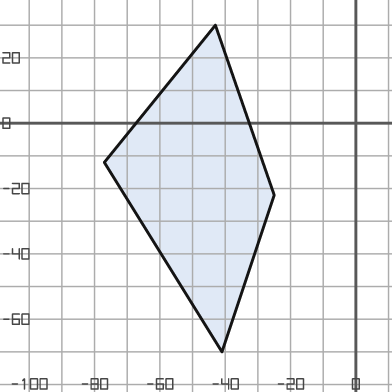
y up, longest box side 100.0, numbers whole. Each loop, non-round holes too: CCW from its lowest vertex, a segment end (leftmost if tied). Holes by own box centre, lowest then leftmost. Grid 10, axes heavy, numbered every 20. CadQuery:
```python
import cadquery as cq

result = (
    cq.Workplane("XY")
    .moveTo(-41.0, -70.0)
    .lineTo(-25.0, -22.0)
    .lineTo(-43.0, 30.0)
    .lineTo(-77.0, -12.0)
    .close()
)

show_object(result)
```